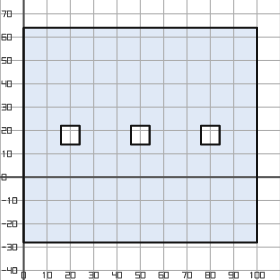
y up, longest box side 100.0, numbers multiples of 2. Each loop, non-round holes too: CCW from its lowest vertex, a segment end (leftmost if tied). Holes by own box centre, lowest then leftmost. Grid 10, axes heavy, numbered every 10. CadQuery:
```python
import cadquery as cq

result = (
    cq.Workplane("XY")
    .moveTo(0.0, -28.0)
    .lineTo(100.0, -28.0)
    .lineTo(100.0, 64.0)
    .lineTo(0.0, 64.0)
    .close()
    .moveTo(16.0, 14.0)
    .lineTo(24.0, 14.0)
    .lineTo(24.0, 22.0)
    .lineTo(16.0, 22.0)
    .close()
    .moveTo(46.0, 14.0)
    .lineTo(54.0, 14.0)
    .lineTo(54.0, 22.0)
    .lineTo(46.0, 22.0)
    .close()
    .moveTo(76.0, 14.0)
    .lineTo(84.0, 14.0)
    .lineTo(84.0, 22.0)
    .lineTo(76.0, 22.0)
    .close()
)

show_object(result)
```